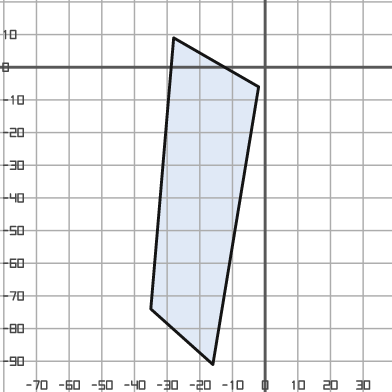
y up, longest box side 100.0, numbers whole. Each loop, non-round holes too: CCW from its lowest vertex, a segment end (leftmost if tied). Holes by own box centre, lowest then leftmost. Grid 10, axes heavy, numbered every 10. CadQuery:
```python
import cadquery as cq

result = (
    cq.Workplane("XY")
    .moveTo(-16.0, -91.0)
    .lineTo(-2.0, -6.0)
    .lineTo(-28.0, 9.0)
    .lineTo(-35.0, -74.0)
    .close()
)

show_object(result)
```